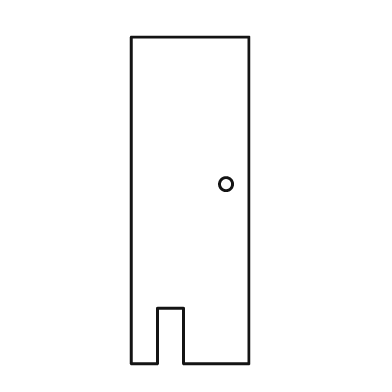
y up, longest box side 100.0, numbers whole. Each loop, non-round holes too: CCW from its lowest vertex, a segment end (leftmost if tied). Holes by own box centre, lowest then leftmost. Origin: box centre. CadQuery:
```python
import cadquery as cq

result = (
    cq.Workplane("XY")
    .moveTo(-18.0, -50.0)
    .lineTo(-10.0, -50.0)
    .lineTo(-10.0, -33.0)
    .lineTo(-2.0, -33.0)
    .lineTo(-2.0, -50.0)
    .lineTo(18.0, -50.0)
    .lineTo(18.0, 50.0)
    .lineTo(-18.0, 50.0)
    .close()
    .moveTo(11.0, 5.0)
    .circle(2.0)
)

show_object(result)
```